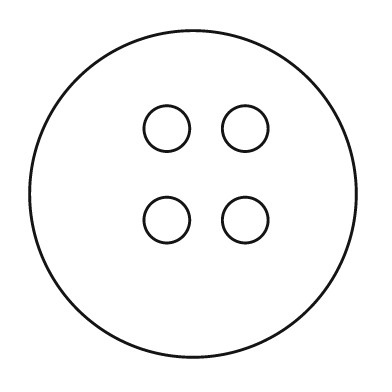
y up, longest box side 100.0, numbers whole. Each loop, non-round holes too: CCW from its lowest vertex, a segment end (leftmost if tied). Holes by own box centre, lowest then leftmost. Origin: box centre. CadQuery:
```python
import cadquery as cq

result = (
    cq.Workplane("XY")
    .moveTo(0.0, 0.0)
    .circle(50.0)
    .moveTo(-8.0, -8.0)
    .circle(7.0)
    .moveTo(16.0, -8.0)
    .circle(7.0)
    .moveTo(-8.0, 20.0)
    .circle(7.0)
    .moveTo(16.0, 20.0)
    .circle(7.0)
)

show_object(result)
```